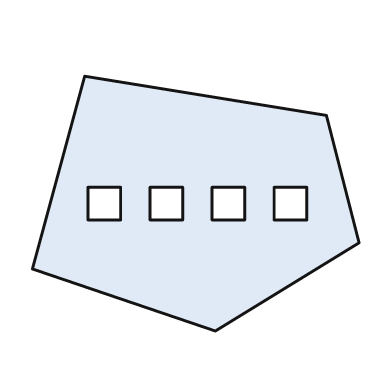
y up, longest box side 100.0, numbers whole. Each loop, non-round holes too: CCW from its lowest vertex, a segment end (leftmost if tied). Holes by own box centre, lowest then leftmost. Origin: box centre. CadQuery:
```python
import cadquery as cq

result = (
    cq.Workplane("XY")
    .moveTo(6.0, -39.0)
    .lineTo(50.0, -12.0)
    .lineTo(40.0, 27.0)
    .lineTo(-34.0, 39.0)
    .lineTo(-50.0, -20.0)
    .close()
    .moveTo(-33.0, -5.0)
    .lineTo(-23.0, -5.0)
    .lineTo(-23.0, 5.0)
    .lineTo(-33.0, 5.0)
    .close()
    .moveTo(-14.0, -5.0)
    .lineTo(-4.0, -5.0)
    .lineTo(-4.0, 5.0)
    .lineTo(-14.0, 5.0)
    .close()
    .moveTo(5.0, -5.0)
    .lineTo(15.0, -5.0)
    .lineTo(15.0, 5.0)
    .lineTo(5.0, 5.0)
    .close()
    .moveTo(24.0, -5.0)
    .lineTo(34.0, -5.0)
    .lineTo(34.0, 5.0)
    .lineTo(24.0, 5.0)
    .close()
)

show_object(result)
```